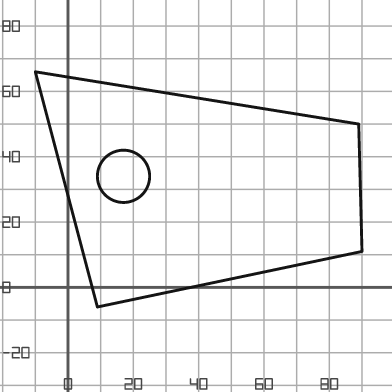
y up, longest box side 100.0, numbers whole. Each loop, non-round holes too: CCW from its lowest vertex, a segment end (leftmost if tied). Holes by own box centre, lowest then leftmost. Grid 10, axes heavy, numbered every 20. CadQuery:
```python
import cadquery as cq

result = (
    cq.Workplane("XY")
    .moveTo(9.0, -6.0)
    .lineTo(90.0, 11.0)
    .lineTo(89.0, 50.0)
    .lineTo(-10.0, 66.0)
    .close()
    .moveTo(17.0, 34.0)
    .circle(8.0)
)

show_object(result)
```